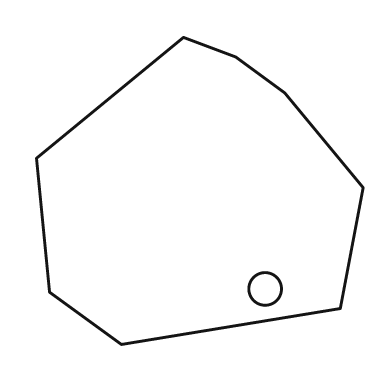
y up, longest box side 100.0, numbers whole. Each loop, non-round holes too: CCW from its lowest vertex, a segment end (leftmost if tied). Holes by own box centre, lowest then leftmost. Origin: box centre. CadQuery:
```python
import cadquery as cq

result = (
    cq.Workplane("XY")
    .moveTo(-24.0, -47.0)
    .lineTo(43.0, -36.0)
    .lineTo(50.0, 1.0)
    .lineTo(26.0, 30.0)
    .lineTo(11.0, 41.0)
    .lineTo(-5.0, 47.0)
    .lineTo(-50.0, 10.0)
    .lineTo(-46.0, -31.0)
    .close()
    .moveTo(20.0, -30.0)
    .circle(5.0)
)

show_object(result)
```